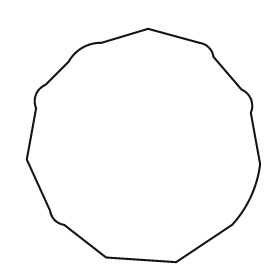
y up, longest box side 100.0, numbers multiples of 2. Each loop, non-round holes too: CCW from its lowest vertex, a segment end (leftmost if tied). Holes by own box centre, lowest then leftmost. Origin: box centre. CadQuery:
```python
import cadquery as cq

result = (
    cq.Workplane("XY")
    .moveTo(14.0, -50.0)
    .lineTo(38.0, -34.0)
    .threePointArc((46.0, -22.0), (50.0, -8.0))
    .lineTo(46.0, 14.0)
    .threePointArc((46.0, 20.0), (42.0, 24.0))
    .lineTo(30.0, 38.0)
    .threePointArc((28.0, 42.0), (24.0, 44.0))
    .lineTo(2.0, 50.0)
    .lineTo(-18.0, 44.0)
    .threePointArc((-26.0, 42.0), (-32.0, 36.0))
    .lineTo(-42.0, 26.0)
    .threePointArc((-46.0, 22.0), (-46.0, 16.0))
    .lineTo(-50.0, -6.0)
    .lineTo(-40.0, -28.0)
    .threePointArc((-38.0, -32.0), (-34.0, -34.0))
    .lineTo(-16.0, -48.0)
    .close()
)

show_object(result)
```